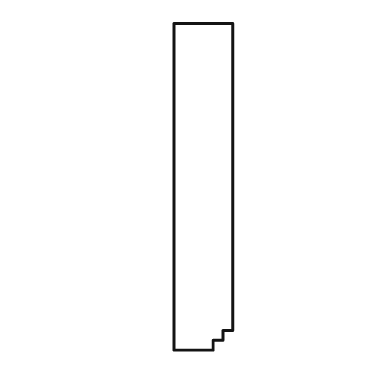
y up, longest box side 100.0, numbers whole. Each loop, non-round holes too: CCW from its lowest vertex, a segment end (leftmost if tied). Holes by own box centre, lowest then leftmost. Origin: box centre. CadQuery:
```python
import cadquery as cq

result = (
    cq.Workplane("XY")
    .moveTo(-9.0, -50.0)
    .lineTo(3.0, -50.0)
    .lineTo(3.0, -47.0)
    .lineTo(6.0, -47.0)
    .lineTo(6.0, -44.0)
    .lineTo(9.0, -44.0)
    .lineTo(9.0, 50.0)
    .lineTo(-9.0, 50.0)
    .close()
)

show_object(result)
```